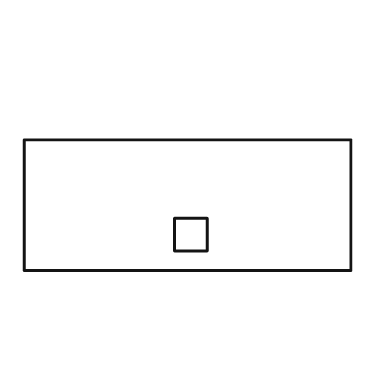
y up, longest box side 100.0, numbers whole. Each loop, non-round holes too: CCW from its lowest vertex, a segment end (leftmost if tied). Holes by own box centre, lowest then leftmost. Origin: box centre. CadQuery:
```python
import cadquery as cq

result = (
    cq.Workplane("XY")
    .moveTo(-50.0, -20.0)
    .lineTo(50.0, -20.0)
    .lineTo(50.0, 20.0)
    .lineTo(-50.0, 20.0)
    .close()
    .moveTo(-4.0, -14.0)
    .lineTo(6.0, -14.0)
    .lineTo(6.0, -4.0)
    .lineTo(-4.0, -4.0)
    .close()
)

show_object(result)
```